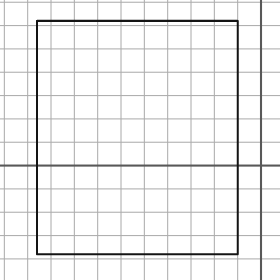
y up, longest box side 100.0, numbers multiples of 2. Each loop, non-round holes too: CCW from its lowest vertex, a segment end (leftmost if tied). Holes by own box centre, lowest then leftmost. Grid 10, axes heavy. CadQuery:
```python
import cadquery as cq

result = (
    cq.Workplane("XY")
    .moveTo(-96.0, -38.0)
    .lineTo(-10.0, -38.0)
    .lineTo(-10.0, 62.0)
    .lineTo(-96.0, 62.0)
    .close()
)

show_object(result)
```